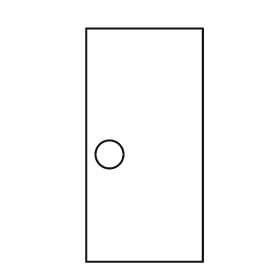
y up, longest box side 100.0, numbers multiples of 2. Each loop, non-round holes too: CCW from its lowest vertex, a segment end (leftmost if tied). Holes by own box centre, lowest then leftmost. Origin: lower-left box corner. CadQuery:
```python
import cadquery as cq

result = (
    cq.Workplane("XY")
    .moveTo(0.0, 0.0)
    .lineTo(50.0, 0.0)
    .lineTo(50.0, 100.0)
    .lineTo(0.0, 100.0)
    .close()
    .moveTo(10.0, 46.0)
    .circle(6.0)
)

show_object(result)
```